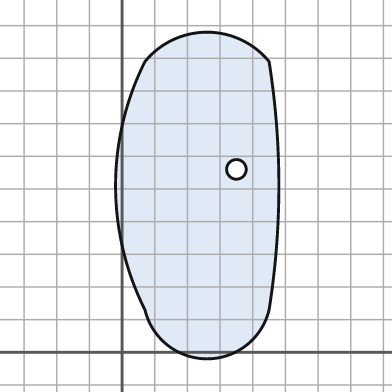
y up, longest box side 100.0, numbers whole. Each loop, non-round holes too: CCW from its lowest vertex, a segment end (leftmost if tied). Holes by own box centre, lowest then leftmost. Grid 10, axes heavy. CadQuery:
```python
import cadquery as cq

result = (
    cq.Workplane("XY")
    .moveTo(7.0, 13.0)
    .threePointArc((26.0, -2.0), (45.0, 13.0))
    .threePointArc((48.0, 51.0), (45.0, 89.0))
    .threePointArc((26.0, 98.0), (7.0, 89.0))
    .threePointArc((-2.0, 51.0), (7.0, 13.0))
    .close()
    .moveTo(35.0, 56.0)
    .circle(3.0)
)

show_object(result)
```